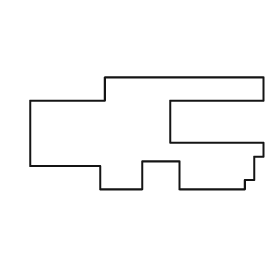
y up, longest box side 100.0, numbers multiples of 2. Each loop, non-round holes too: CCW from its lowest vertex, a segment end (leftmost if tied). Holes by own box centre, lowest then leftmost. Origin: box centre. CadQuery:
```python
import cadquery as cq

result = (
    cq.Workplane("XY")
    .moveTo(-20.0, -24.0)
    .lineTo(-2.0, -24.0)
    .lineTo(-2.0, -12.0)
    .lineTo(14.0, -12.0)
    .lineTo(14.0, -24.0)
    .lineTo(42.0, -24.0)
    .lineTo(42.0, -20.0)
    .lineTo(46.0, -20.0)
    .lineTo(46.0, -10.0)
    .lineTo(50.0, -10.0)
    .lineTo(50.0, -4.0)
    .lineTo(10.0, -4.0)
    .lineTo(10.0, 14.0)
    .lineTo(50.0, 14.0)
    .lineTo(50.0, 24.0)
    .lineTo(-18.0, 24.0)
    .lineTo(-18.0, 14.0)
    .lineTo(-50.0, 14.0)
    .lineTo(-50.0, -14.0)
    .lineTo(-20.0, -14.0)
    .close()
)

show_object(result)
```